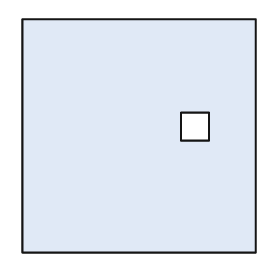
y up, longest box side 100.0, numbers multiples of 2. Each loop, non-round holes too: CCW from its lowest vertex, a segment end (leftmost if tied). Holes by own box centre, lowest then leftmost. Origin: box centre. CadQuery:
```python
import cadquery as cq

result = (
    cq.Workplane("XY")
    .moveTo(-50.0, -50.0)
    .lineTo(50.0, -50.0)
    .lineTo(50.0, 50.0)
    .lineTo(-50.0, 50.0)
    .close()
    .moveTo(18.0, -2.0)
    .lineTo(30.0, -2.0)
    .lineTo(30.0, 10.0)
    .lineTo(18.0, 10.0)
    .close()
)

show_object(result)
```